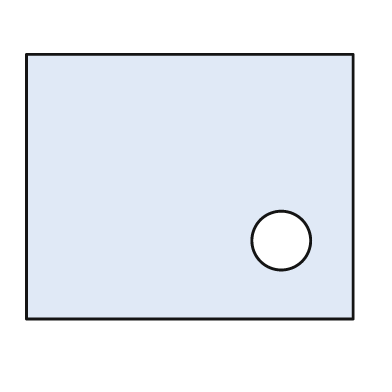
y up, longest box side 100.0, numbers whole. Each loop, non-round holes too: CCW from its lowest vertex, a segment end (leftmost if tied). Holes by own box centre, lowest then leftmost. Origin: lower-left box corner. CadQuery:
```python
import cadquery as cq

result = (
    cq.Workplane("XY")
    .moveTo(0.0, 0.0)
    .lineTo(100.0, 0.0)
    .lineTo(100.0, 81.0)
    .lineTo(0.0, 81.0)
    .close()
    .moveTo(78.0, 24.0)
    .circle(9.0)
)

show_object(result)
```